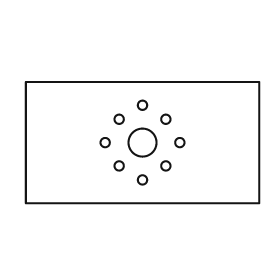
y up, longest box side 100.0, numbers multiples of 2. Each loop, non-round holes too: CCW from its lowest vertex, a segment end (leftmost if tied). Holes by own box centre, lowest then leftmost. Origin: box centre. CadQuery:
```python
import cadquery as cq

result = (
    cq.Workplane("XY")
    .moveTo(-50.0, -26.0)
    .lineTo(50.0, -26.0)
    .lineTo(50.0, 26.0)
    .lineTo(-50.0, 26.0)
    .close()
    .moveTo(0.0, -16.0)
    .circle(2.0)
    .moveTo(-10.0, -10.0)
    .circle(2.0)
    .moveTo(10.0, -10.0)
    .circle(2.0)
    .moveTo(-16.0, 0.0)
    .circle(2.0)
    .moveTo(0.0, 0.0)
    .circle(6.0)
    .moveTo(16.0, 0.0)
    .circle(2.0)
    .moveTo(-10.0, 10.0)
    .circle(2.0)
    .moveTo(10.0, 10.0)
    .circle(2.0)
    .moveTo(0.0, 16.0)
    .circle(2.0)
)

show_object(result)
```